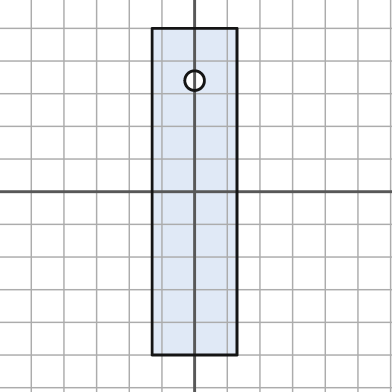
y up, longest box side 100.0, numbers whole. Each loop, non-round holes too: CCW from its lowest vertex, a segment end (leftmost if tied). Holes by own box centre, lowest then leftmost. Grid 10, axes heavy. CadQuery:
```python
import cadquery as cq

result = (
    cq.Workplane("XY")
    .moveTo(-13.0, -50.0)
    .lineTo(13.0, -50.0)
    .lineTo(13.0, 50.0)
    .lineTo(-13.0, 50.0)
    .close()
    .moveTo(0.0, 34.0)
    .circle(3.0)
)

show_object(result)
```